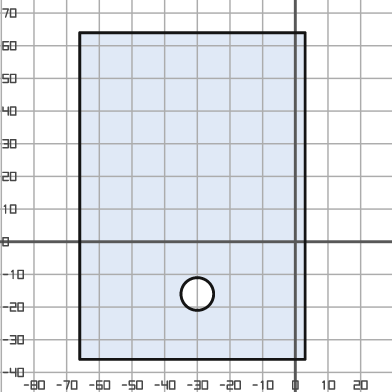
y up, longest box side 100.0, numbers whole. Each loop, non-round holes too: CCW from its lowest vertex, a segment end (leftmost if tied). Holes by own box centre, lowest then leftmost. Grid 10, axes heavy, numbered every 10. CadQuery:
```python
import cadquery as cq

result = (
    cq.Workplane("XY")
    .moveTo(-66.0, -36.0)
    .lineTo(3.0, -36.0)
    .lineTo(3.0, 64.0)
    .lineTo(-66.0, 64.0)
    .close()
    .moveTo(-30.0, -16.0)
    .circle(5.0)
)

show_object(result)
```